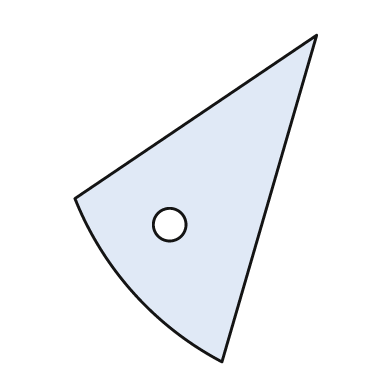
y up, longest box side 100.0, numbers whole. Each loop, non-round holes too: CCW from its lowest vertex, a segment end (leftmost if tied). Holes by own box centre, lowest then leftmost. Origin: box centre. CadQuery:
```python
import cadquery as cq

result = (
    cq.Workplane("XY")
    .moveTo(8.0, -50.0)
    .lineTo(37.0, 50.0)
    .lineTo(-37.0, 0.0)
    .threePointArc((-19.0, -29.0), (8.0, -50.0))
    .close()
    .moveTo(-8.0, -8.0)
    .circle(5.0)
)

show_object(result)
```